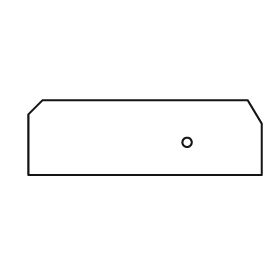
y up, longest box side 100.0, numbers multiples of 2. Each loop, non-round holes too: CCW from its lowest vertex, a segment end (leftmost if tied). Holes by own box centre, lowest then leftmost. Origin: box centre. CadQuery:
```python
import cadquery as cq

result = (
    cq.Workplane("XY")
    .moveTo(-50.0, -16.0)
    .lineTo(50.0, -16.0)
    .lineTo(50.0, 6.0)
    .lineTo(44.0, 16.0)
    .lineTo(-44.0, 16.0)
    .lineTo(-50.0, 10.0)
    .close()
    .moveTo(18.0, -2.0)
    .circle(2.0)
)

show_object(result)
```